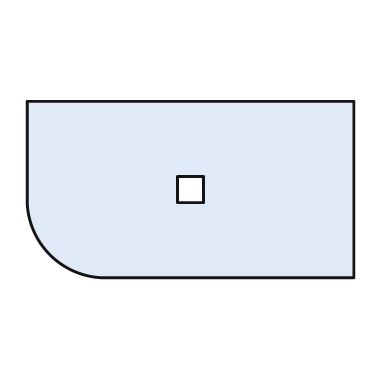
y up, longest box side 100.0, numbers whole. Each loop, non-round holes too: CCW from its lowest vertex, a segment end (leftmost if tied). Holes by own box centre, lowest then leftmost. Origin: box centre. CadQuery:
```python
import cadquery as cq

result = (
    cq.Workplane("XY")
    .moveTo(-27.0, -27.0)
    .lineTo(50.0, -27.0)
    .lineTo(50.0, 27.0)
    .lineTo(-50.0, 27.0)
    .lineTo(-50.0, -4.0)
    .threePointArc((-43.0, -20.0), (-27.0, -27.0))
    .close()
    .moveTo(-4.0, -4.0)
    .lineTo(4.0, -4.0)
    .lineTo(4.0, 4.0)
    .lineTo(-4.0, 4.0)
    .close()
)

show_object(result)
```